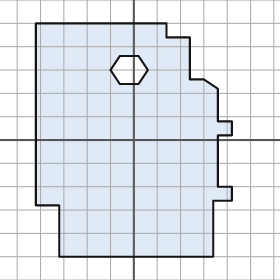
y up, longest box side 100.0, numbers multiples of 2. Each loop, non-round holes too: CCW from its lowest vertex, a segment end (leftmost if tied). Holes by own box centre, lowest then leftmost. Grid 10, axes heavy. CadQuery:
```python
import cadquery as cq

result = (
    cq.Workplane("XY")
    .moveTo(-32.0, -50.0)
    .lineTo(34.0, -50.0)
    .lineTo(34.0, -26.0)
    .lineTo(42.0, -26.0)
    .lineTo(42.0, -20.0)
    .lineTo(36.0, -20.0)
    .lineTo(36.0, 2.0)
    .lineTo(42.0, 2.0)
    .lineTo(42.0, 8.0)
    .lineTo(36.0, 8.0)
    .lineTo(36.0, 22.0)
    .lineTo(30.0, 26.0)
    .lineTo(24.0, 26.0)
    .lineTo(24.0, 44.0)
    .lineTo(14.0, 44.0)
    .lineTo(14.0, 50.0)
    .lineTo(-42.0, 50.0)
    .lineTo(-42.0, -28.0)
    .lineTo(-32.0, -28.0)
    .close()
    .moveTo(-6.0, 24.0)
    .lineTo(2.0, 24.0)
    .lineTo(6.0, 30.0)
    .lineTo(2.0, 36.0)
    .lineTo(-6.0, 36.0)
    .lineTo(-10.0, 30.0)
    .close()
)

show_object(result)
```